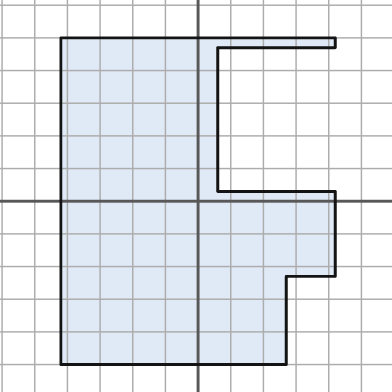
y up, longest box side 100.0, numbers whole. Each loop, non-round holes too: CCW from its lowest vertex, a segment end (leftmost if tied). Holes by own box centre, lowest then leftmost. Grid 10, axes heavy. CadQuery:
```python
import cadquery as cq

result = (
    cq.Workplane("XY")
    .moveTo(-42.0, -50.0)
    .lineTo(27.0, -50.0)
    .lineTo(27.0, -23.0)
    .lineTo(42.0, -23.0)
    .lineTo(42.0, 3.0)
    .lineTo(6.0, 3.0)
    .lineTo(6.0, 47.0)
    .lineTo(42.0, 47.0)
    .lineTo(42.0, 50.0)
    .lineTo(-42.0, 50.0)
    .close()
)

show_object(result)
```